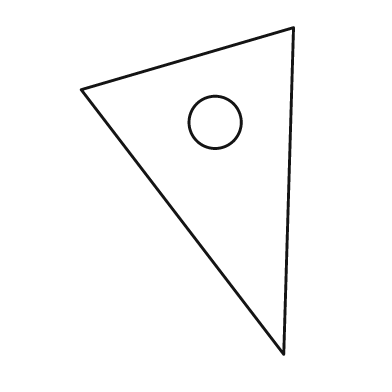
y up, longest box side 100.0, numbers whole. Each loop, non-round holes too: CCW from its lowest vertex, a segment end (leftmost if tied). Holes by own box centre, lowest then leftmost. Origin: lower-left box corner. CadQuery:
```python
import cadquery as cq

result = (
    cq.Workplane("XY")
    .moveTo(62.0, 0.0)
    .lineTo(65.0, 100.0)
    .lineTo(0.0, 81.0)
    .close()
    .moveTo(41.0, 71.0)
    .circle(8.0)
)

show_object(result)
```